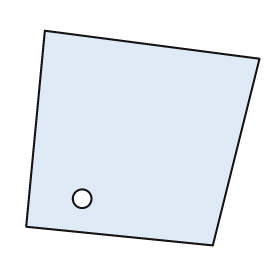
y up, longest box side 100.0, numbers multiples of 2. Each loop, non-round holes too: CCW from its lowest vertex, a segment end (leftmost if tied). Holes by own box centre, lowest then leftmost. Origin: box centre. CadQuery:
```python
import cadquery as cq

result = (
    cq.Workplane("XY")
    .moveTo(30.0, -46.0)
    .lineTo(50.0, 34.0)
    .lineTo(-42.0, 46.0)
    .lineTo(-50.0, -38.0)
    .close()
    .moveTo(-26.0, -26.0)
    .circle(4.0)
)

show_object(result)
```